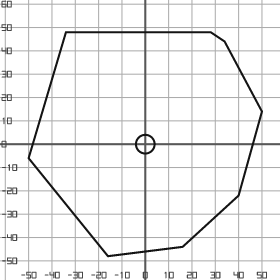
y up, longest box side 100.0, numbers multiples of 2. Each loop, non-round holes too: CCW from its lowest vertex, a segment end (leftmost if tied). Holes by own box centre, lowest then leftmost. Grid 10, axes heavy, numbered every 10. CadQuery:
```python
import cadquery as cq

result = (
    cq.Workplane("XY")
    .moveTo(-16.0, -48.0)
    .lineTo(16.0, -44.0)
    .lineTo(40.0, -22.0)
    .lineTo(50.0, 14.0)
    .lineTo(34.0, 44.0)
    .lineTo(28.0, 48.0)
    .lineTo(-34.0, 48.0)
    .lineTo(-50.0, -6.0)
    .close()
    .moveTo(0.0, 0.0)
    .circle(4.0)
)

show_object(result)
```